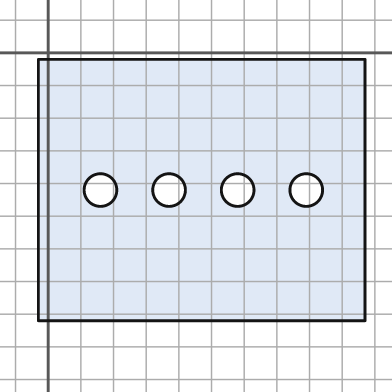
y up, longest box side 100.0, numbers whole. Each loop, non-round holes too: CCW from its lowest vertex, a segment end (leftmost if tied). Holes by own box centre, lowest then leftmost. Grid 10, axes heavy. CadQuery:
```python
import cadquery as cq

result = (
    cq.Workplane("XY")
    .moveTo(-3.0, -82.0)
    .lineTo(97.0, -82.0)
    .lineTo(97.0, -2.0)
    .lineTo(-3.0, -2.0)
    .close()
    .moveTo(16.0, -42.0)
    .circle(5.0)
    .moveTo(37.0, -42.0)
    .circle(5.0)
    .moveTo(58.0, -42.0)
    .circle(5.0)
    .moveTo(79.0, -42.0)
    .circle(5.0)
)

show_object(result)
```